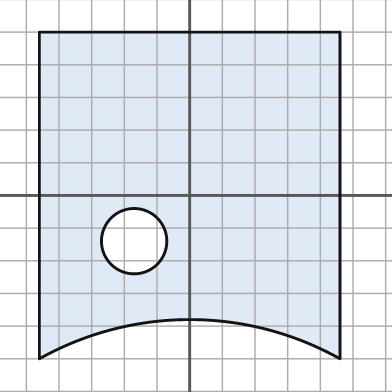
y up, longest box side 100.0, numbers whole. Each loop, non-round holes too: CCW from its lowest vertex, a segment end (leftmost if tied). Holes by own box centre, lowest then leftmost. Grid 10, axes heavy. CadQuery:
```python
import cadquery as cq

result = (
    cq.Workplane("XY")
    .moveTo(-46.0, -50.0)
    .threePointArc((0.0, -38.0), (46.0, -50.0))
    .lineTo(46.0, 50.0)
    .lineTo(-46.0, 50.0)
    .close()
    .moveTo(-17.0, -14.0)
    .circle(10.0)
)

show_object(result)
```